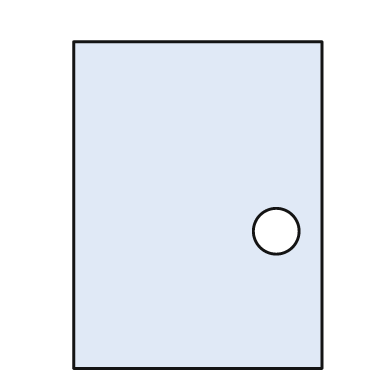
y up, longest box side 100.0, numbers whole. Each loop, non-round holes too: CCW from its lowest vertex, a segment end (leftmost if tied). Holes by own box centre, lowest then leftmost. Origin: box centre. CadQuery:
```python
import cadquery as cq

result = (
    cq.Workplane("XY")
    .moveTo(-38.0, -50.0)
    .lineTo(38.0, -50.0)
    .lineTo(38.0, 50.0)
    .lineTo(-38.0, 50.0)
    .close()
    .moveTo(24.0, -8.0)
    .circle(7.0)
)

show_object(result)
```